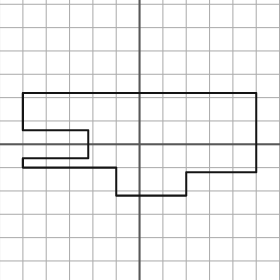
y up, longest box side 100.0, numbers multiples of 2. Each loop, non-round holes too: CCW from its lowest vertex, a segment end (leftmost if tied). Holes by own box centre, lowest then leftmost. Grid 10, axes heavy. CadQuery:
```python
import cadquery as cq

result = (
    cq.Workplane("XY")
    .moveTo(-10.0, -22.0)
    .lineTo(20.0, -22.0)
    .lineTo(20.0, -12.0)
    .lineTo(50.0, -12.0)
    .lineTo(50.0, 22.0)
    .lineTo(-50.0, 22.0)
    .lineTo(-50.0, 6.0)
    .lineTo(-22.0, 6.0)
    .lineTo(-22.0, -6.0)
    .lineTo(-50.0, -6.0)
    .lineTo(-50.0, -10.0)
    .lineTo(-10.0, -10.0)
    .close()
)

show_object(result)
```